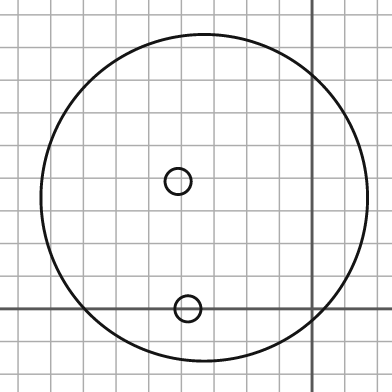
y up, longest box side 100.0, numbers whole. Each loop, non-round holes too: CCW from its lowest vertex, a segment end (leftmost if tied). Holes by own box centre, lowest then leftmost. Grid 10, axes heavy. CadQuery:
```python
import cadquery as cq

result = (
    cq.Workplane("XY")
    .moveTo(-33.0, 34.0)
    .circle(50.0)
    .moveTo(-38.0, 0.0)
    .circle(4.0)
    .moveTo(-41.0, 39.0)
    .circle(4.0)
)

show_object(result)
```